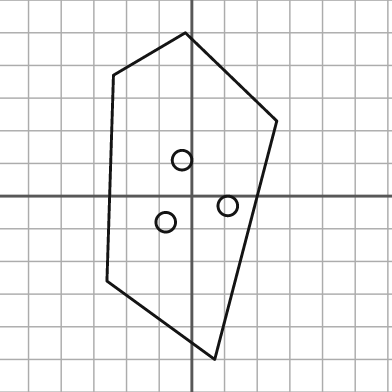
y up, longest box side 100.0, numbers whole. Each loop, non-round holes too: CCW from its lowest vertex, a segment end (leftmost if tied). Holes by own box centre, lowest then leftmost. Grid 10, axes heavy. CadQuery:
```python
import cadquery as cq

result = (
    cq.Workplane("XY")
    .moveTo(7.0, -50.0)
    .lineTo(26.0, 23.0)
    .lineTo(-2.0, 50.0)
    .lineTo(-24.0, 37.0)
    .lineTo(-26.0, -26.0)
    .close()
    .moveTo(-8.0, -8.0)
    .circle(3.0)
    .moveTo(11.0, -3.0)
    .circle(3.0)
    .moveTo(-3.0, 11.0)
    .circle(3.0)
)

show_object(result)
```